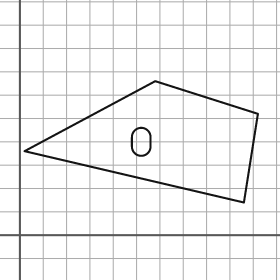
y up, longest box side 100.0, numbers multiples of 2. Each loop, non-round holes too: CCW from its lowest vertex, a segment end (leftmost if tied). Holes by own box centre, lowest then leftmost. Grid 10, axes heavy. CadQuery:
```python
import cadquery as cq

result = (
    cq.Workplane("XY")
    .moveTo(96.0, 14.0)
    .lineTo(102.0, 52.0)
    .lineTo(58.0, 66.0)
    .lineTo(2.0, 36.0)
    .close()
    .moveTo(48.0, 38.0)
    .threePointArc((52.0, 34.0), (56.0, 38.0))
    .lineTo(56.0, 42.0)
    .threePointArc((52.0, 46.0), (48.0, 42.0))
    .close()
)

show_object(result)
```